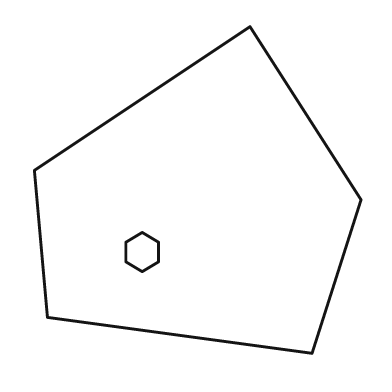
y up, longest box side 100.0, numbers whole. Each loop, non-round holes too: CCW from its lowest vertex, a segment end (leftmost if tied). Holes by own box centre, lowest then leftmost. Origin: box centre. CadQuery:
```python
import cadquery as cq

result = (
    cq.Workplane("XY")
    .moveTo(35.0, -50.0)
    .lineTo(50.0, -3.0)
    .lineTo(16.0, 50.0)
    .lineTo(-50.0, 6.0)
    .lineTo(-46.0, -39.0)
    .close()
    .moveTo(-17.0, -25.0)
    .lineTo(-12.0, -22.0)
    .lineTo(-12.0, -16.0)
    .lineTo(-17.0, -13.0)
    .lineTo(-22.0, -16.0)
    .lineTo(-22.0, -22.0)
    .close()
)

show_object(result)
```